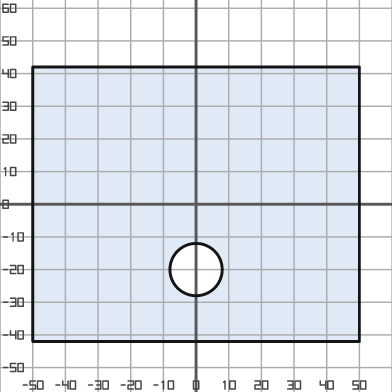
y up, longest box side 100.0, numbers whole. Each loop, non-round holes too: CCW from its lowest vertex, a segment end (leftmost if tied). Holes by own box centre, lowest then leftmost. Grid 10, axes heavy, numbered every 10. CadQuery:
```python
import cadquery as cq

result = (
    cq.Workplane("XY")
    .moveTo(-50.0, -42.0)
    .lineTo(50.0, -42.0)
    .lineTo(50.0, 42.0)
    .lineTo(-50.0, 42.0)
    .close()
    .moveTo(0.0, -20.0)
    .circle(8.0)
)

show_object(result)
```